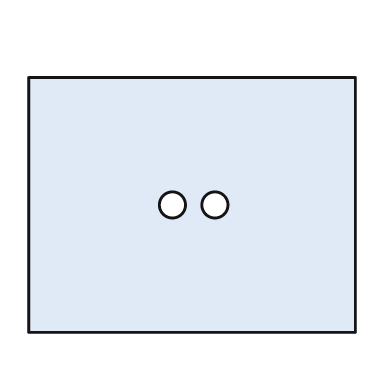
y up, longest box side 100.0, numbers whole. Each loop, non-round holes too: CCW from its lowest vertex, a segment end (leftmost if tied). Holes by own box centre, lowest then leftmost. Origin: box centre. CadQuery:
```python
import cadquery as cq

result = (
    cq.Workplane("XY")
    .moveTo(-50.0, -39.0)
    .lineTo(50.0, -39.0)
    .lineTo(50.0, 39.0)
    .lineTo(-50.0, 39.0)
    .close()
    .moveTo(-6.0, 0.0)
    .circle(4.0)
    .moveTo(7.0, 0.0)
    .circle(4.0)
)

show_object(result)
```